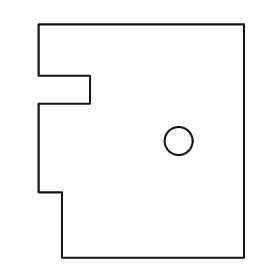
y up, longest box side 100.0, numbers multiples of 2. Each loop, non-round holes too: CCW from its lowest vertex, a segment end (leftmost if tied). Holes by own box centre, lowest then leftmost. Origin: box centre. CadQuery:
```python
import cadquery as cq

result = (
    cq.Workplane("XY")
    .moveTo(-34.0, -50.0)
    .lineTo(44.0, -50.0)
    .lineTo(44.0, 50.0)
    .lineTo(-44.0, 50.0)
    .lineTo(-44.0, 28.0)
    .lineTo(-22.0, 28.0)
    .lineTo(-22.0, 16.0)
    .lineTo(-44.0, 16.0)
    .lineTo(-44.0, -22.0)
    .lineTo(-34.0, -22.0)
    .close()
    .moveTo(16.0, 0.0)
    .circle(6.0)
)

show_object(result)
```